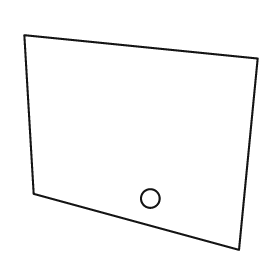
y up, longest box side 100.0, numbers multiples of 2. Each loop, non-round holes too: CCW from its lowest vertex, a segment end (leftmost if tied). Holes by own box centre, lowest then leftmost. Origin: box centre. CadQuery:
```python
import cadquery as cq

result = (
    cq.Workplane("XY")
    .moveTo(42.0, -46.0)
    .lineTo(50.0, 36.0)
    .lineTo(-50.0, 46.0)
    .lineTo(-46.0, -22.0)
    .close()
    .moveTo(4.0, -24.0)
    .circle(4.0)
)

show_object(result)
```